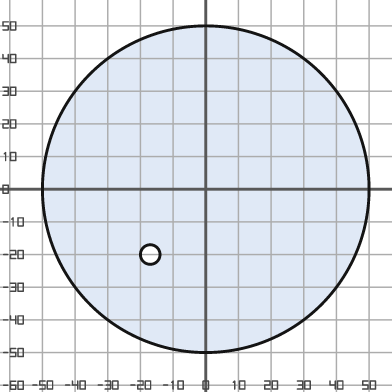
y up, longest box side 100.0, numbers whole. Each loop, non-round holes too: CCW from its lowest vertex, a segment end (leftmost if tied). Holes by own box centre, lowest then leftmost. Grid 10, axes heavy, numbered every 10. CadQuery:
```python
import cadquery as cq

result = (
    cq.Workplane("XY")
    .moveTo(0.0, 0.0)
    .circle(50.0)
    .moveTo(-17.0, -20.0)
    .circle(3.0)
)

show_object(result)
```